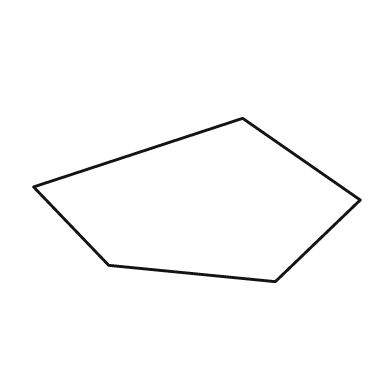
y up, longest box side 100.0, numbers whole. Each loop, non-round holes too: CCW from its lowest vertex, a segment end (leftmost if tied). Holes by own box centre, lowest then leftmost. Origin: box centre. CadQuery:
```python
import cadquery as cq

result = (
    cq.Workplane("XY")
    .moveTo(24.0, -25.0)
    .lineTo(50.0, 0.0)
    .lineTo(14.0, 25.0)
    .lineTo(-50.0, 4.0)
    .lineTo(-27.0, -20.0)
    .close()
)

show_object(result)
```